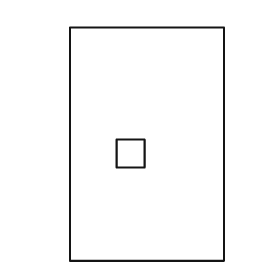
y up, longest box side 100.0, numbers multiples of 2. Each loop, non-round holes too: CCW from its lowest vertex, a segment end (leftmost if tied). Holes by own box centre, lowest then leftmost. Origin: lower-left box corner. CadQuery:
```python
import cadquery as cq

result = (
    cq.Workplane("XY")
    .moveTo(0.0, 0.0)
    .lineTo(66.0, 0.0)
    .lineTo(66.0, 100.0)
    .lineTo(0.0, 100.0)
    .close()
    .moveTo(20.0, 40.0)
    .lineTo(32.0, 40.0)
    .lineTo(32.0, 52.0)
    .lineTo(20.0, 52.0)
    .close()
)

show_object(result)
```